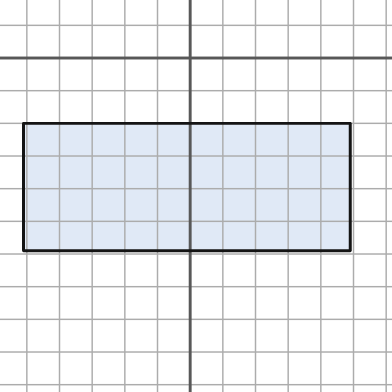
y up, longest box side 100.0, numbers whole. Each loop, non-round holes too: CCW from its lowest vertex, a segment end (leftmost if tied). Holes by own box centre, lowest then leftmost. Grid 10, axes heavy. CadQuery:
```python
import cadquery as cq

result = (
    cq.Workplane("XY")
    .moveTo(-51.0, -59.0)
    .lineTo(49.0, -59.0)
    .lineTo(49.0, -20.0)
    .lineTo(-51.0, -20.0)
    .close()
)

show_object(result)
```